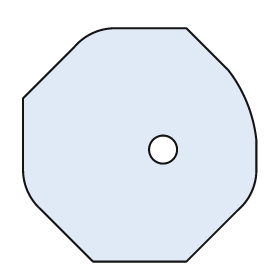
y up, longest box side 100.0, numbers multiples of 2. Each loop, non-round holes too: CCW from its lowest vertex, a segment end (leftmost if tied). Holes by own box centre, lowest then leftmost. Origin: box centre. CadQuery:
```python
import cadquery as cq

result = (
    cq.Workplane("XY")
    .moveTo(-20.0, -50.0)
    .lineTo(20.0, -50.0)
    .lineTo(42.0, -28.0)
    .threePointArc((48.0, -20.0), (50.0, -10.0))
    .lineTo(50.0, 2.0)
    .threePointArc((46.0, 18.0), (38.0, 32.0))
    .lineTo(20.0, 50.0)
    .lineTo(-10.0, 50.0)
    .threePointArc((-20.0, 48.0), (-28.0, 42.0))
    .lineTo(-50.0, 20.0)
    .lineTo(-50.0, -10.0)
    .threePointArc((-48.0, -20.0), (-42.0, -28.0))
    .close()
    .moveTo(10.0, -2.0)
    .circle(6.0)
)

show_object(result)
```